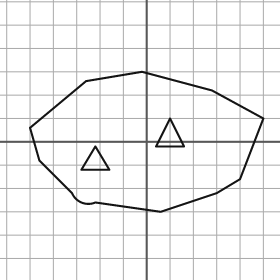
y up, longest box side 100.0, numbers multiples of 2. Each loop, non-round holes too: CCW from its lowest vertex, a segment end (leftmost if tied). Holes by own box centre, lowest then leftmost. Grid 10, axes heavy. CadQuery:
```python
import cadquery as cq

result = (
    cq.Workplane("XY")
    .moveTo(6.0, -30.0)
    .lineTo(30.0, -22.0)
    .lineTo(40.0, -16.0)
    .lineTo(50.0, 10.0)
    .lineTo(28.0, 22.0)
    .lineTo(-2.0, 30.0)
    .lineTo(-26.0, 26.0)
    .lineTo(-50.0, 6.0)
    .lineTo(-46.0, -8.0)
    .lineTo(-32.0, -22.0)
    .threePointArc((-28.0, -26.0), (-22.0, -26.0))
    .close()
    .moveTo(-28.0, -12.0)
    .lineTo(-16.0, -12.0)
    .lineTo(-22.0, -2.0)
    .close()
    .moveTo(4.0, -2.0)
    .lineTo(16.0, -2.0)
    .lineTo(10.0, 10.0)
    .close()
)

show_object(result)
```